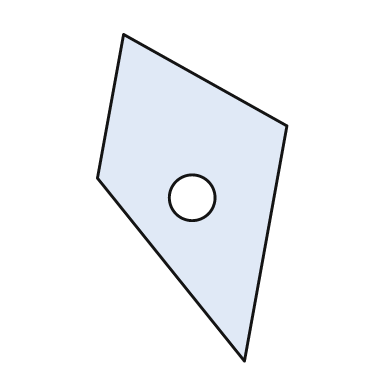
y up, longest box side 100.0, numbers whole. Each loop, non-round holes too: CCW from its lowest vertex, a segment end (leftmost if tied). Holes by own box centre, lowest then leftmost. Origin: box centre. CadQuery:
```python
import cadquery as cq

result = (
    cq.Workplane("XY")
    .moveTo(16.0, -50.0)
    .lineTo(29.0, 22.0)
    .lineTo(-21.0, 50.0)
    .lineTo(-29.0, 6.0)
    .close()
    .moveTo(0.0, 0.0)
    .circle(7.0)
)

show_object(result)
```